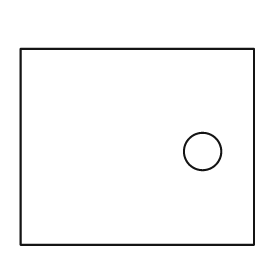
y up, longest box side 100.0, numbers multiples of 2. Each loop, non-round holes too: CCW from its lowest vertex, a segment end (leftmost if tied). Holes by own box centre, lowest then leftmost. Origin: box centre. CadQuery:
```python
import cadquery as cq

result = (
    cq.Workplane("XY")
    .moveTo(-50.0, -42.0)
    .lineTo(50.0, -42.0)
    .lineTo(50.0, 42.0)
    .lineTo(-50.0, 42.0)
    .close()
    .moveTo(28.0, -2.0)
    .circle(8.0)
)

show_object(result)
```